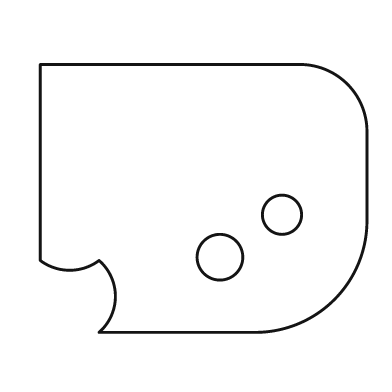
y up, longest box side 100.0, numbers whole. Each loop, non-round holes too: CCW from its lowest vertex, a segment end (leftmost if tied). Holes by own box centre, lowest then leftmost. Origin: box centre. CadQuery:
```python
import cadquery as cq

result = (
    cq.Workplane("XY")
    .moveTo(-32.0, -41.0)
    .lineTo(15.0, -41.0)
    .threePointArc((40.0, -31.0), (50.0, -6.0))
    .lineTo(50.0, 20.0)
    .threePointArc((44.0, 35.0), (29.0, 41.0))
    .lineTo(-50.0, 41.0)
    .lineTo(-50.0, -19.0)
    .threePointArc((-41.0, -22.0), (-32.0, -19.0))
    .threePointArc((-27.0, -30.0), (-32.0, -41.0))
    .close()
    .moveTo(5.0, -18.0)
    .circle(7.0)
    .moveTo(24.0, -5.0)
    .circle(6.0)
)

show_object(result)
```